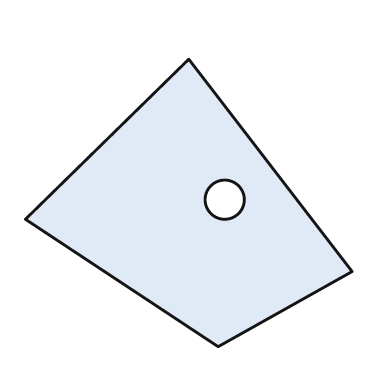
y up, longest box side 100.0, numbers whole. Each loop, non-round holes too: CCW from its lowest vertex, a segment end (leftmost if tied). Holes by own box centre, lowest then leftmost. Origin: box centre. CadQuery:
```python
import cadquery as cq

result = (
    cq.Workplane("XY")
    .moveTo(9.0, -44.0)
    .lineTo(50.0, -21.0)
    .lineTo(0.0, 44.0)
    .lineTo(-50.0, -5.0)
    .close()
    .moveTo(11.0, 1.0)
    .circle(6.0)
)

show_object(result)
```